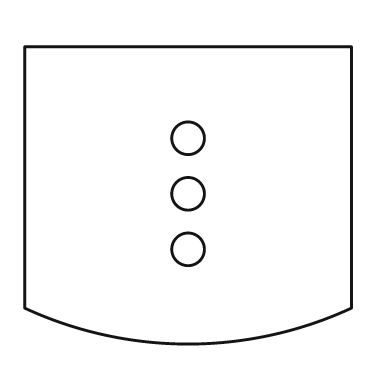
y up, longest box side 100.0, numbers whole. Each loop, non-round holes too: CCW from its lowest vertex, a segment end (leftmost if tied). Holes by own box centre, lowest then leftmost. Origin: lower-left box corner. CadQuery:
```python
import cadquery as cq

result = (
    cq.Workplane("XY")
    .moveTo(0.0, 11.0)
    .threePointArc((50.0, 0.0), (100.0, 11.0))
    .lineTo(100.0, 91.0)
    .lineTo(0.0, 91.0)
    .close()
    .moveTo(50.0, 29.0)
    .circle(5.0)
    .moveTo(50.0, 46.0)
    .circle(5.0)
    .moveTo(50.0, 63.0)
    .circle(5.0)
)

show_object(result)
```